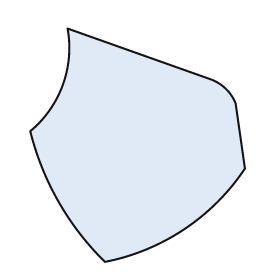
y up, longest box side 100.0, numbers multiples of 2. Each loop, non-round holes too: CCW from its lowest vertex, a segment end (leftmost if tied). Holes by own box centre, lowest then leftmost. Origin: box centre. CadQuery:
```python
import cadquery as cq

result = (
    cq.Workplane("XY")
    .moveTo(-14.0, -50.0)
    .threePointArc((20.0, -36.0), (46.0, -10.0))
    .lineTo(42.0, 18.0)
    .threePointArc((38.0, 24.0), (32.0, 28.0))
    .lineTo(-30.0, 50.0)
    .threePointArc((-32.0, 26.0), (-46.0, 6.0))
    .threePointArc((-34.0, -24.0), (-14.0, -50.0))
    .close()
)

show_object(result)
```